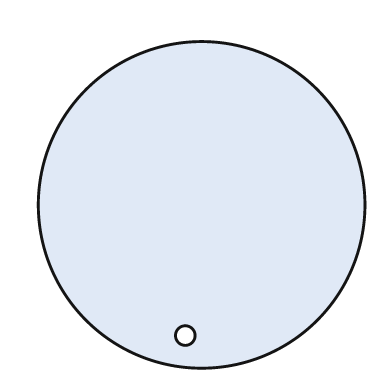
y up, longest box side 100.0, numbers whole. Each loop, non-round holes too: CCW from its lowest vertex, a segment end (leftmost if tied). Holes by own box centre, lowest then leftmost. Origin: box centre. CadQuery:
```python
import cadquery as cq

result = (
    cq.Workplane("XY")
    .moveTo(0.0, 0.0)
    .circle(50.0)
    .moveTo(-5.0, -40.0)
    .circle(3.0)
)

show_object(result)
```